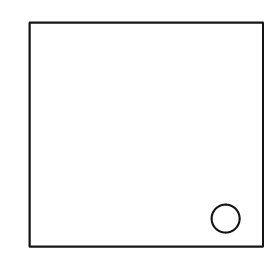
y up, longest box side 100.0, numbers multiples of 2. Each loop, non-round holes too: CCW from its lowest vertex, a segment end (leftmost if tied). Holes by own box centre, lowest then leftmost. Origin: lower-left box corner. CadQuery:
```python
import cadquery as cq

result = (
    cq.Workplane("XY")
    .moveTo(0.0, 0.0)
    .lineTo(100.0, 0.0)
    .lineTo(100.0, 96.0)
    .lineTo(0.0, 96.0)
    .close()
    .moveTo(84.0, 12.0)
    .circle(6.0)
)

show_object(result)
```